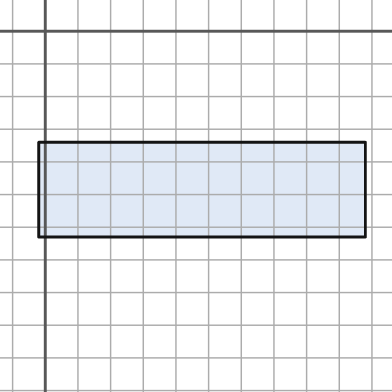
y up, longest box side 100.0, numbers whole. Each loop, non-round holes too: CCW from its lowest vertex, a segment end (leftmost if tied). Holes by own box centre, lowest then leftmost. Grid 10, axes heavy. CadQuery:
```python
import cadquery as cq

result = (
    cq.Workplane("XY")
    .moveTo(-2.0, -63.0)
    .lineTo(98.0, -63.0)
    .lineTo(98.0, -34.0)
    .lineTo(-2.0, -34.0)
    .close()
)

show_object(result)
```